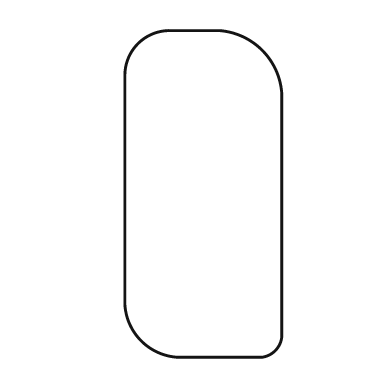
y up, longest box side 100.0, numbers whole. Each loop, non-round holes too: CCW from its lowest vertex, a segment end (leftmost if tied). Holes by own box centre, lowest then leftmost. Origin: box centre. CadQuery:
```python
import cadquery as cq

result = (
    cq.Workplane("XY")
    .moveTo(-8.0, -50.0)
    .lineTo(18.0, -50.0)
    .threePointArc((22.0, -48.0), (24.0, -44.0))
    .lineTo(24.0, 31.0)
    .threePointArc((18.0, 44.0), (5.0, 50.0))
    .lineTo(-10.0, 50.0)
    .threePointArc((-20.0, 46.0), (-24.0, 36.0))
    .lineTo(-24.0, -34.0)
    .threePointArc((-19.0, -45.0), (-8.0, -50.0))
    .close()
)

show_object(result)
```